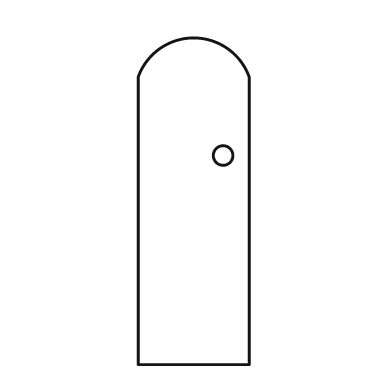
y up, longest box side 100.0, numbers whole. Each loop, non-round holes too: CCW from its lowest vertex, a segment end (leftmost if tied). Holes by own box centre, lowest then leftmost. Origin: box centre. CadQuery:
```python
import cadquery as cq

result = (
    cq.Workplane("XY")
    .moveTo(-17.0, -50.0)
    .lineTo(17.0, -50.0)
    .lineTo(17.0, 38.0)
    .threePointArc((0.0, 50.0), (-17.0, 38.0))
    .close()
    .moveTo(9.0, 14.0)
    .circle(3.0)
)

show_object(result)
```